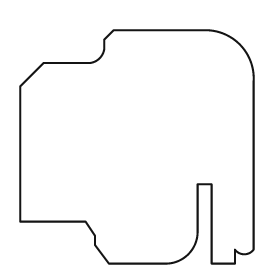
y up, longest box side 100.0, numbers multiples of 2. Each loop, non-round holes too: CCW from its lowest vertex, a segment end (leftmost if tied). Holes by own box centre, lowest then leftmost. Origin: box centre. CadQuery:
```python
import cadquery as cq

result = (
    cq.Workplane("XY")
    .moveTo(-12.0, -50.0)
    .lineTo(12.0, -50.0)
    .threePointArc((22.0, -46.0), (26.0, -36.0))
    .lineTo(26.0, -16.0)
    .lineTo(32.0, -16.0)
    .lineTo(32.0, -50.0)
    .lineTo(42.0, -50.0)
    .lineTo(42.0, -44.0)
    .threePointArc((46.0, -46.0), (50.0, -44.0))
    .lineTo(50.0, 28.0)
    .threePointArc((44.0, 44.0), (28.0, 50.0))
    .lineTo(-10.0, 50.0)
    .lineTo(-14.0, 46.0)
    .lineTo(-14.0, 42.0)
    .threePointArc((-16.0, 38.0), (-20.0, 36.0))
    .lineTo(-40.0, 36.0)
    .lineTo(-50.0, 26.0)
    .lineTo(-50.0, -32.0)
    .lineTo(-22.0, -32.0)
    .lineTo(-18.0, -38.0)
    .lineTo(-18.0, -42.0)
    .close()
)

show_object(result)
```